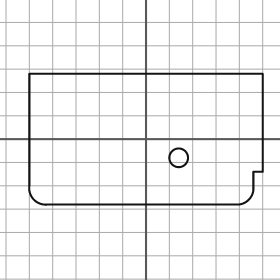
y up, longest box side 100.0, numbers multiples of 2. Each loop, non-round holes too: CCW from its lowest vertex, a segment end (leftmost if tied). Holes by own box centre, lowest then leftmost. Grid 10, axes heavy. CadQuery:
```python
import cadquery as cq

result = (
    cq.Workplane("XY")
    .moveTo(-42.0, -28.0)
    .lineTo(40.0, -28.0)
    .threePointArc((44.0, -26.0), (46.0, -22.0))
    .lineTo(46.0, -14.0)
    .lineTo(50.0, -14.0)
    .lineTo(50.0, 28.0)
    .lineTo(-50.0, 28.0)
    .lineTo(-50.0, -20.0)
    .threePointArc((-48.0, -26.0), (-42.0, -28.0))
    .close()
    .moveTo(14.0, -8.0)
    .circle(4.0)
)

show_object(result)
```